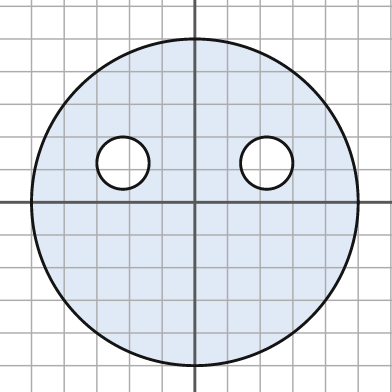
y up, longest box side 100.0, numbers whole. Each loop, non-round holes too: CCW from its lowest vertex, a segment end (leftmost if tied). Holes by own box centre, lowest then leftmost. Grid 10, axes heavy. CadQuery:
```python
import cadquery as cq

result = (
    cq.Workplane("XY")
    .moveTo(0.0, 0.0)
    .circle(50.0)
    .moveTo(-22.0, 12.0)
    .circle(8.0)
    .moveTo(22.0, 12.0)
    .circle(8.0)
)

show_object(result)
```